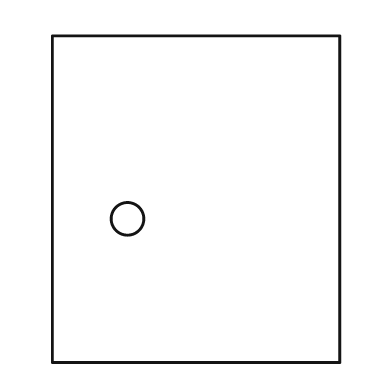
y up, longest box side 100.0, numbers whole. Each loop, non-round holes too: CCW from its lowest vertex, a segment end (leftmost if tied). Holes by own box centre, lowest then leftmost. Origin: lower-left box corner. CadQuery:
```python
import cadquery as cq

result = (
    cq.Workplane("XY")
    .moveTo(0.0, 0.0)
    .lineTo(88.0, 0.0)
    .lineTo(88.0, 100.0)
    .lineTo(0.0, 100.0)
    .close()
    .moveTo(23.0, 44.0)
    .circle(5.0)
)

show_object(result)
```